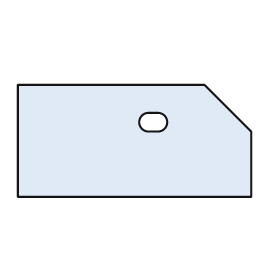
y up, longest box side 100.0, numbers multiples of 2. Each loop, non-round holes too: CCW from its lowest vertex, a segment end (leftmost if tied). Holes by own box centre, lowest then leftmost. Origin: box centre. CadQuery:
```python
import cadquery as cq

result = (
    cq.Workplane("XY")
    .moveTo(-50.0, -24.0)
    .lineTo(50.0, -24.0)
    .lineTo(50.0, 4.0)
    .lineTo(30.0, 24.0)
    .lineTo(-50.0, 24.0)
    .close()
    .moveTo(6.0, 4.0)
    .lineTo(10.0, 4.0)
    .threePointArc((14.0, 8.0), (10.0, 12.0))
    .lineTo(6.0, 12.0)
    .threePointArc((2.0, 8.0), (6.0, 4.0))
    .close()
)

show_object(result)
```